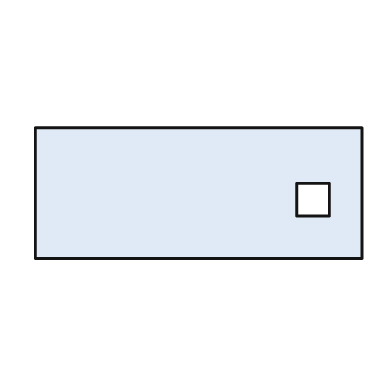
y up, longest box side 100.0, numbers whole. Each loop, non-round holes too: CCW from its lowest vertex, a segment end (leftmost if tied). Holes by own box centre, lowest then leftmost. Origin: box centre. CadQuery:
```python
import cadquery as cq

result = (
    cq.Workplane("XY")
    .moveTo(-50.0, -20.0)
    .lineTo(50.0, -20.0)
    .lineTo(50.0, 20.0)
    .lineTo(-50.0, 20.0)
    .close()
    .moveTo(30.0, -7.0)
    .lineTo(40.0, -7.0)
    .lineTo(40.0, 3.0)
    .lineTo(30.0, 3.0)
    .close()
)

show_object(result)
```